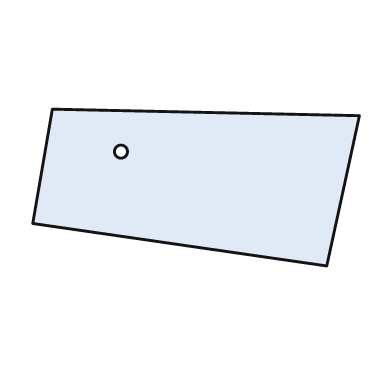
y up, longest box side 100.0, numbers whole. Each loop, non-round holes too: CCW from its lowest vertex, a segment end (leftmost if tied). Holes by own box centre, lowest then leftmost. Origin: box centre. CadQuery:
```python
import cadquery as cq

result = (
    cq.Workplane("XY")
    .moveTo(40.0, -24.0)
    .lineTo(50.0, 22.0)
    .lineTo(-44.0, 24.0)
    .lineTo(-50.0, -11.0)
    .close()
    .moveTo(-23.0, 11.0)
    .circle(2.0)
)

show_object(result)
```